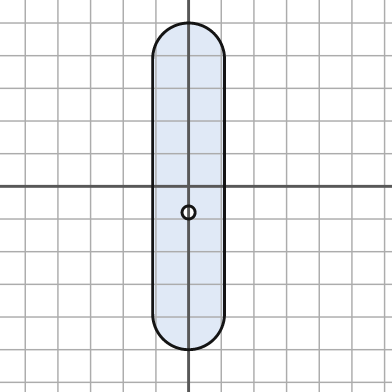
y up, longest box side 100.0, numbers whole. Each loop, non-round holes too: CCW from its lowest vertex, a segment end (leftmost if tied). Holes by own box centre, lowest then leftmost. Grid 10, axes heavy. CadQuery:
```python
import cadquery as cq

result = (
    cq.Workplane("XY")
    .moveTo(-11.0, -39.0)
    .threePointArc((0.0, -50.0), (11.0, -39.0))
    .lineTo(11.0, 39.0)
    .threePointArc((0.0, 50.0), (-11.0, 39.0))
    .close()
    .moveTo(0.0, -8.0)
    .circle(2.0)
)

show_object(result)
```